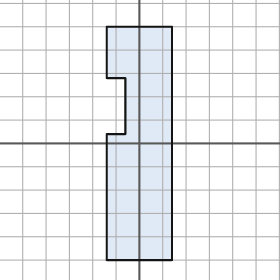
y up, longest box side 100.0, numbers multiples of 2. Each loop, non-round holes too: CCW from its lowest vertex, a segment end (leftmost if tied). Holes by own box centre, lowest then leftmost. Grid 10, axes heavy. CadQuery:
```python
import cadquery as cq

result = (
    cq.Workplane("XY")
    .moveTo(-14.0, -50.0)
    .lineTo(14.0, -50.0)
    .lineTo(14.0, 50.0)
    .lineTo(-14.0, 50.0)
    .lineTo(-14.0, 28.0)
    .lineTo(-6.0, 28.0)
    .lineTo(-6.0, 4.0)
    .lineTo(-14.0, 4.0)
    .close()
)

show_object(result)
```